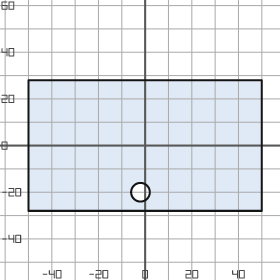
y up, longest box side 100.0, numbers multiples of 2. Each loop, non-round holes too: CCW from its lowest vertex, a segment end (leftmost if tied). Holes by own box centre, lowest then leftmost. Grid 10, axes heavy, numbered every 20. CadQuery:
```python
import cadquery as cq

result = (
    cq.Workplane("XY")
    .moveTo(-50.0, -28.0)
    .lineTo(50.0, -28.0)
    .lineTo(50.0, 28.0)
    .lineTo(-50.0, 28.0)
    .close()
    .moveTo(-2.0, -20.0)
    .circle(4.0)
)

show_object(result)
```